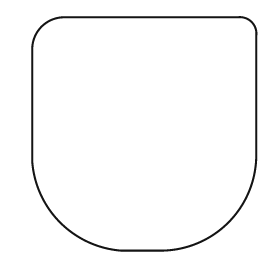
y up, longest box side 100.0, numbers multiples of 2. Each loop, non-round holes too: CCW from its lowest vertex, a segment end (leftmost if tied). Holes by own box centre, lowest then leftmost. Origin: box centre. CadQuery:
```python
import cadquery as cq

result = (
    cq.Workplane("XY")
    .moveTo(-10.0, -50.0)
    .lineTo(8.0, -50.0)
    .threePointArc((36.0, -38.0), (48.0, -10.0))
    .lineTo(48.0, 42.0)
    .threePointArc((46.0, 48.0), (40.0, 50.0))
    .lineTo(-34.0, 50.0)
    .threePointArc((-44.0, 46.0), (-48.0, 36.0))
    .lineTo(-48.0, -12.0)
    .threePointArc((-36.0, -38.0), (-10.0, -50.0))
    .close()
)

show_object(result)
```